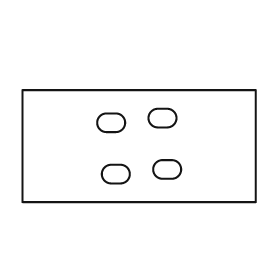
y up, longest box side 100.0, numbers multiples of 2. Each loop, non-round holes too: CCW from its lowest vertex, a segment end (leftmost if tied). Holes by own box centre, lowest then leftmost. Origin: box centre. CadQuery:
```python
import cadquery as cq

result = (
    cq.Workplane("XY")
    .moveTo(-50.0, -24.0)
    .lineTo(50.0, -24.0)
    .lineTo(50.0, 24.0)
    .lineTo(-50.0, 24.0)
    .close()
    .moveTo(-12.0, -16.0)
    .lineTo(-8.0, -16.0)
    .threePointArc((-4.0, -12.0), (-8.0, -8.0))
    .lineTo(-12.0, -8.0)
    .threePointArc((-16.0, -12.0), (-12.0, -16.0))
    .close()
    .moveTo(10.0, -14.0)
    .lineTo(14.0, -14.0)
    .threePointArc((18.0, -10.0), (14.0, -6.0))
    .lineTo(10.0, -6.0)
    .threePointArc((6.0, -10.0), (10.0, -14.0))
    .close()
    .moveTo(-14.0, 6.0)
    .lineTo(-10.0, 6.0)
    .threePointArc((-6.0, 10.0), (-10.0, 14.0))
    .lineTo(-14.0, 14.0)
    .threePointArc((-18.0, 10.0), (-14.0, 6.0))
    .close()
    .moveTo(8.0, 8.0)
    .lineTo(12.0, 8.0)
    .threePointArc((16.0, 12.0), (12.0, 16.0))
    .lineTo(8.0, 16.0)
    .threePointArc((4.0, 12.0), (8.0, 8.0))
    .close()
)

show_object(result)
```